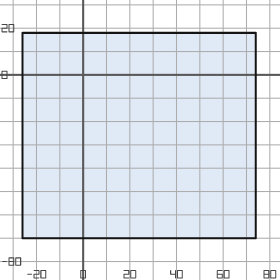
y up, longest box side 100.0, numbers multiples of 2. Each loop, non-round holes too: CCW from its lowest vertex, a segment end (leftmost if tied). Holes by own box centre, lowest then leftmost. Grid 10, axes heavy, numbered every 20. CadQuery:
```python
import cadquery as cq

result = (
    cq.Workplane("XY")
    .moveTo(-26.0, -70.0)
    .lineTo(74.0, -70.0)
    .lineTo(74.0, 18.0)
    .lineTo(-26.0, 18.0)
    .close()
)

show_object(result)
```